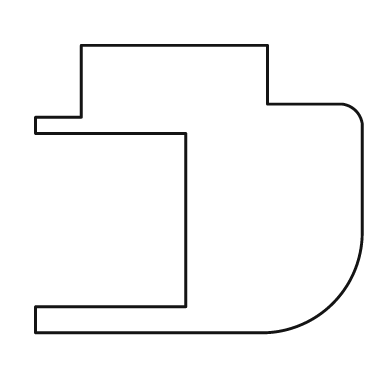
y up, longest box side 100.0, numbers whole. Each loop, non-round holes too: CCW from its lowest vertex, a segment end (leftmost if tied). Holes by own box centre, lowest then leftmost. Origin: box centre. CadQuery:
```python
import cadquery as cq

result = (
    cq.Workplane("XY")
    .moveTo(-50.0, -44.0)
    .lineTo(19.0, -44.0)
    .threePointArc((41.0, -35.0), (50.0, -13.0))
    .lineTo(50.0, 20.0)
    .threePointArc((48.0, 24.0), (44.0, 26.0))
    .lineTo(21.0, 26.0)
    .lineTo(21.0, 44.0)
    .lineTo(-36.0, 44.0)
    .lineTo(-36.0, 22.0)
    .lineTo(-50.0, 22.0)
    .lineTo(-50.0, 17.0)
    .lineTo(-4.0, 17.0)
    .lineTo(-4.0, -36.0)
    .lineTo(-50.0, -36.0)
    .close()
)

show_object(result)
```